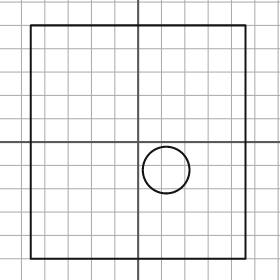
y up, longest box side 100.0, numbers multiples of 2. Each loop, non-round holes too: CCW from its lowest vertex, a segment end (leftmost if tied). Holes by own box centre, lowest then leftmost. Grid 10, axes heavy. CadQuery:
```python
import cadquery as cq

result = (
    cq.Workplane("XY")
    .moveTo(-46.0, -50.0)
    .lineTo(46.0, -50.0)
    .lineTo(46.0, 50.0)
    .lineTo(-46.0, 50.0)
    .close()
    .moveTo(12.0, -12.0)
    .circle(10.0)
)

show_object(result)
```